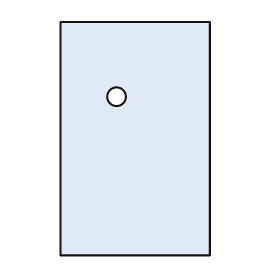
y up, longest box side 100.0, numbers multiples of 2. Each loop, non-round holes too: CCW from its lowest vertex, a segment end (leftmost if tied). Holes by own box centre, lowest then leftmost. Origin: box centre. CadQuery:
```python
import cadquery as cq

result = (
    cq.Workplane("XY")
    .moveTo(-32.0, -50.0)
    .lineTo(32.0, -50.0)
    .lineTo(32.0, 50.0)
    .lineTo(-32.0, 50.0)
    .close()
    .moveTo(-8.0, 18.0)
    .circle(4.0)
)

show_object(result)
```